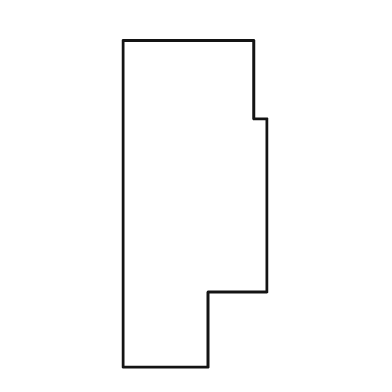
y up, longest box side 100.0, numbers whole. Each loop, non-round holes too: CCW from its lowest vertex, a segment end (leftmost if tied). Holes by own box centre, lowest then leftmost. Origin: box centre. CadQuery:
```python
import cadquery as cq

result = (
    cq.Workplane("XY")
    .moveTo(-22.0, -50.0)
    .lineTo(4.0, -50.0)
    .lineTo(4.0, -27.0)
    .lineTo(22.0, -27.0)
    .lineTo(22.0, 26.0)
    .lineTo(18.0, 26.0)
    .lineTo(18.0, 50.0)
    .lineTo(-22.0, 50.0)
    .close()
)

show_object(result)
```